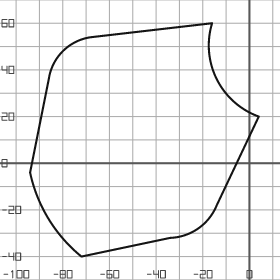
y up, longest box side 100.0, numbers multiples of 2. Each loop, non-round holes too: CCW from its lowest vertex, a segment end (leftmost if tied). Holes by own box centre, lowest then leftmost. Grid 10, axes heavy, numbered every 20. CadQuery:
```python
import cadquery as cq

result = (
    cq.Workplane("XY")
    .moveTo(-72.0, -40.0)
    .lineTo(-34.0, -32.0)
    .threePointArc((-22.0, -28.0), (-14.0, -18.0))
    .lineTo(4.0, 20.0)
    .threePointArc((-14.0, 36.0), (-16.0, 60.0))
    .lineTo(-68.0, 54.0)
    .threePointArc((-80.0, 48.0), (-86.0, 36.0))
    .lineTo(-94.0, -4.0)
    .threePointArc((-86.0, -24.0), (-72.0, -40.0))
    .close()
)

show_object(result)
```